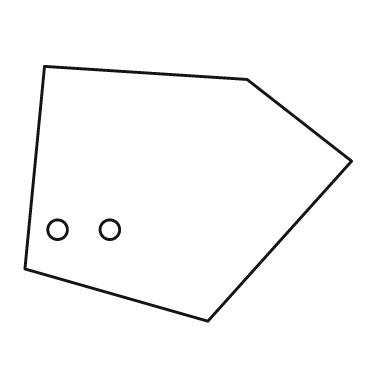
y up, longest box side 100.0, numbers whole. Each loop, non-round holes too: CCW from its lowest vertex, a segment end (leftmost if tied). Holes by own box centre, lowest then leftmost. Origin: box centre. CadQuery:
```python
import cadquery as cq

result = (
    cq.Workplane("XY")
    .moveTo(6.0, -39.0)
    .lineTo(50.0, 10.0)
    .lineTo(18.0, 35.0)
    .lineTo(-44.0, 39.0)
    .lineTo(-50.0, -23.0)
    .close()
    .moveTo(-40.0, -11.0)
    .circle(3.0)
    .moveTo(-24.0, -11.0)
    .circle(3.0)
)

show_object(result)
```